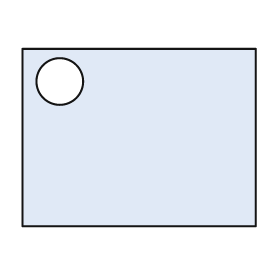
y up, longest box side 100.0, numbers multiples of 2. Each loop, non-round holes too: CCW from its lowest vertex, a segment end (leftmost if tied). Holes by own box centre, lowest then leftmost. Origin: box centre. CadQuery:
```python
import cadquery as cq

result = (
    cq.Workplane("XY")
    .moveTo(-50.0, -38.0)
    .lineTo(50.0, -38.0)
    .lineTo(50.0, 38.0)
    .lineTo(-50.0, 38.0)
    .close()
    .moveTo(-34.0, 24.0)
    .circle(10.0)
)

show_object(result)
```